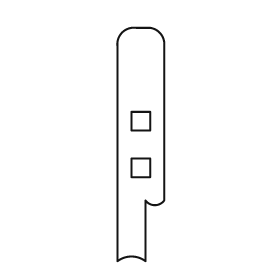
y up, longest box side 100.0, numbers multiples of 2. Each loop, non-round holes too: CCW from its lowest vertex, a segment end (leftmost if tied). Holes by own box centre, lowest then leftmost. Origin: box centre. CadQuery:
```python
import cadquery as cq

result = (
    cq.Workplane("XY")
    .moveTo(-10.0, -50.0)
    .threePointArc((-4.0, -48.0), (2.0, -50.0))
    .lineTo(2.0, -24.0)
    .threePointArc((6.0, -26.0), (10.0, -24.0))
    .lineTo(10.0, 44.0)
    .threePointArc((8.0, 48.0), (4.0, 50.0))
    .lineTo(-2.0, 50.0)
    .threePointArc((-8.0, 48.0), (-10.0, 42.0))
    .close()
    .moveTo(-4.0, -14.0)
    .lineTo(4.0, -14.0)
    .lineTo(4.0, -6.0)
    .lineTo(-4.0, -6.0)
    .close()
    .moveTo(-4.0, 6.0)
    .lineTo(4.0, 6.0)
    .lineTo(4.0, 14.0)
    .lineTo(-4.0, 14.0)
    .close()
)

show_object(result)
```